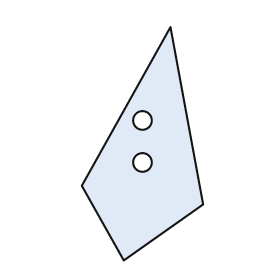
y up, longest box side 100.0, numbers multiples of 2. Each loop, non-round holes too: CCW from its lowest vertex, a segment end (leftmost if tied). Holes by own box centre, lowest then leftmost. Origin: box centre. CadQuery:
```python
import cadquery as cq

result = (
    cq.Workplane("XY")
    .moveTo(-8.0, -50.0)
    .lineTo(26.0, -26.0)
    .lineTo(12.0, 50.0)
    .lineTo(-26.0, -18.0)
    .close()
    .moveTo(0.0, -8.0)
    .circle(4.0)
    .moveTo(0.0, 10.0)
    .circle(4.0)
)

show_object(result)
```